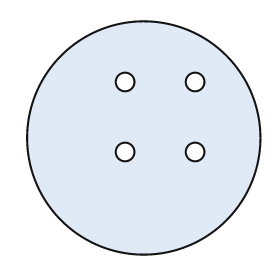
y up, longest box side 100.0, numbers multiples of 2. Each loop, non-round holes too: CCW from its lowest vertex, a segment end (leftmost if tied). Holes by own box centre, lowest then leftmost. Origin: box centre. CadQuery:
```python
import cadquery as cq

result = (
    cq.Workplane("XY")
    .moveTo(0.0, 0.0)
    .circle(50.0)
    .moveTo(-8.0, -6.0)
    .circle(4.0)
    .moveTo(22.0, -6.0)
    .circle(4.0)
    .moveTo(-8.0, 24.0)
    .circle(4.0)
    .moveTo(22.0, 24.0)
    .circle(4.0)
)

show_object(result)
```